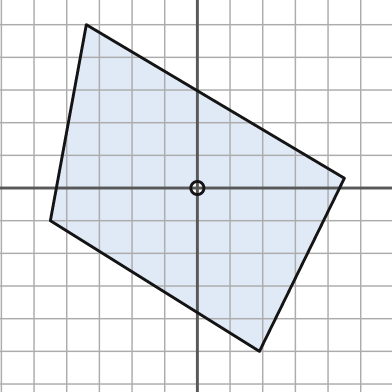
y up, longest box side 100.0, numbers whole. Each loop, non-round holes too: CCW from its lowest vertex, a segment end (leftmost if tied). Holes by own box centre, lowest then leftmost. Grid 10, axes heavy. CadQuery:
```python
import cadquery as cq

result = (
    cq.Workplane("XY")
    .moveTo(19.0, -50.0)
    .lineTo(45.0, 3.0)
    .lineTo(-34.0, 50.0)
    .lineTo(-45.0, -10.0)
    .close()
    .moveTo(0.0, 0.0)
    .circle(2.0)
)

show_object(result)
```